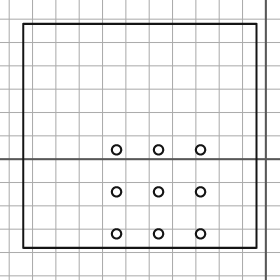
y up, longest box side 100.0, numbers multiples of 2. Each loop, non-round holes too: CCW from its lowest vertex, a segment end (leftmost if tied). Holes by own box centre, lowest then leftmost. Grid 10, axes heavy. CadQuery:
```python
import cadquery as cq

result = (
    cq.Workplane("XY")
    .moveTo(-104.0, -38.0)
    .lineTo(-4.0, -38.0)
    .lineTo(-4.0, 58.0)
    .lineTo(-104.0, 58.0)
    .close()
    .moveTo(-64.0, -32.0)
    .circle(2.0)
    .moveTo(-46.0, -32.0)
    .circle(2.0)
    .moveTo(-28.0, -32.0)
    .circle(2.0)
    .moveTo(-64.0, -14.0)
    .circle(2.0)
    .moveTo(-46.0, -14.0)
    .circle(2.0)
    .moveTo(-28.0, -14.0)
    .circle(2.0)
    .moveTo(-64.0, 4.0)
    .circle(2.0)
    .moveTo(-46.0, 4.0)
    .circle(2.0)
    .moveTo(-28.0, 4.0)
    .circle(2.0)
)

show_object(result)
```